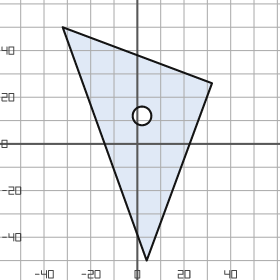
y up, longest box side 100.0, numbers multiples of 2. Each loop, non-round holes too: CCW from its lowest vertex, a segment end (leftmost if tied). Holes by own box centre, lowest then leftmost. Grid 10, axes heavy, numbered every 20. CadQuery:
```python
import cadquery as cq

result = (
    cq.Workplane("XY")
    .moveTo(4.0, -50.0)
    .lineTo(32.0, 26.0)
    .lineTo(-32.0, 50.0)
    .close()
    .moveTo(2.0, 12.0)
    .circle(4.0)
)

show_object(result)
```